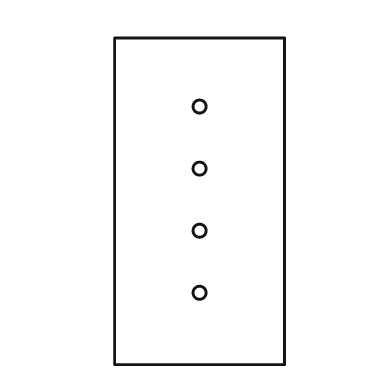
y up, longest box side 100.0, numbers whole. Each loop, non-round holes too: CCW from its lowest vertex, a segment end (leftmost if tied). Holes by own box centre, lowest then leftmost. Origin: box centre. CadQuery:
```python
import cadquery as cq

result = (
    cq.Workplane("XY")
    .moveTo(-26.0, -50.0)
    .lineTo(26.0, -50.0)
    .lineTo(26.0, 50.0)
    .lineTo(-26.0, 50.0)
    .close()
    .moveTo(0.0, -28.0)
    .circle(2.0)
    .moveTo(0.0, -9.0)
    .circle(2.0)
    .moveTo(0.0, 10.0)
    .circle(2.0)
    .moveTo(0.0, 29.0)
    .circle(2.0)
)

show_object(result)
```